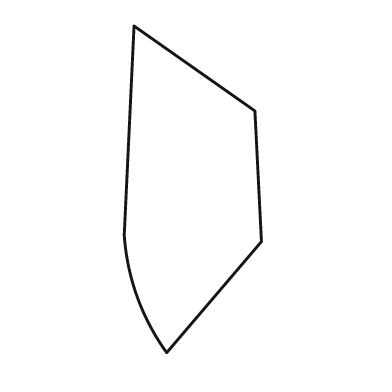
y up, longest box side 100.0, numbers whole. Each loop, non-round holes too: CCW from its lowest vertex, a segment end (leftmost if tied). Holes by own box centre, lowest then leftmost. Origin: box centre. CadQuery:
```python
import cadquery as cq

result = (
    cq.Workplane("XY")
    .moveTo(-8.0, -50.0)
    .lineTo(21.0, -16.0)
    .lineTo(19.0, 24.0)
    .lineTo(-18.0, 50.0)
    .lineTo(-21.0, -14.0)
    .threePointArc((-17.0, -33.0), (-8.0, -50.0))
    .close()
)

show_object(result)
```